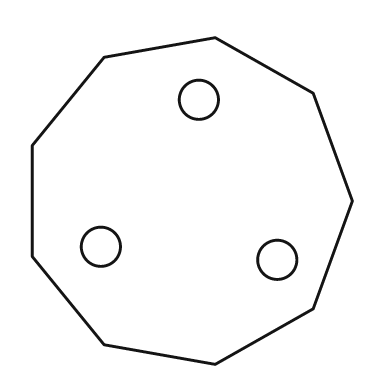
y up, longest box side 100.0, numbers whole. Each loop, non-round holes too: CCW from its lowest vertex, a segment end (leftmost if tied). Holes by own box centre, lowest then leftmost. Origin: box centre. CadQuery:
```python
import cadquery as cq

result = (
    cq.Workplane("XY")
    .moveTo(7.0, -50.0)
    .lineTo(37.0, -33.0)
    .lineTo(49.0, 0.0)
    .lineTo(37.0, 33.0)
    .lineTo(7.0, 50.0)
    .lineTo(-27.0, 44.0)
    .lineTo(-49.0, 17.0)
    .lineTo(-49.0, -17.0)
    .lineTo(-27.0, -44.0)
    .close()
    .moveTo(26.0, -18.0)
    .circle(6.0)
    .moveTo(-28.0, -14.0)
    .circle(6.0)
    .moveTo(2.0, 31.0)
    .circle(6.0)
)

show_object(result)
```